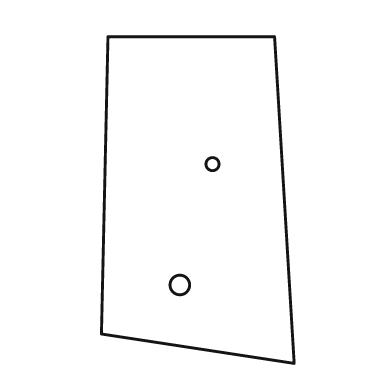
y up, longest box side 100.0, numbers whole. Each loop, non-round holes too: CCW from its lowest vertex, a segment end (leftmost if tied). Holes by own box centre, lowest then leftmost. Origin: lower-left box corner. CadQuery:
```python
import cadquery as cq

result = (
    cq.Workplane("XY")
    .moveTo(59.0, 0.0)
    .lineTo(53.0, 100.0)
    .lineTo(2.0, 100.0)
    .lineTo(0.0, 9.0)
    .close()
    .moveTo(24.0, 24.0)
    .circle(3.0)
    .moveTo(34.0, 61.0)
    .circle(2.0)
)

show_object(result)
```